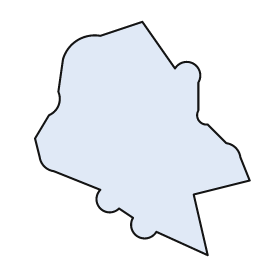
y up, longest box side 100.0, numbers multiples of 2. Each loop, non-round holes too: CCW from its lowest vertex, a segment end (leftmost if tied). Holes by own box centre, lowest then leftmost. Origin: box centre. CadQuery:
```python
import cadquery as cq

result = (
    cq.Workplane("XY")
    .moveTo(28.0, -50.0)
    .lineTo(22.0, -24.0)
    .lineTo(46.0, -18.0)
    .lineTo(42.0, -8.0)
    .threePointArc((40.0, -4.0), (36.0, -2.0))
    .lineTo(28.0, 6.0)
    .threePointArc((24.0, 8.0), (24.0, 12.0))
    .lineTo(24.0, 24.0)
    .threePointArc((22.0, 32.0), (14.0, 30.0))
    .lineTo(0.0, 50.0)
    .lineTo(-18.0, 44.0)
    .threePointArc((-28.0, 42.0), (-34.0, 34.0))
    .lineTo(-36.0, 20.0)
    .threePointArc((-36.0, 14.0), (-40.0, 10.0))
    .lineTo(-46.0, 0.0)
    .lineTo(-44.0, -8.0)
    .threePointArc((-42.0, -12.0), (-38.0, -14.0))
    .lineTo(-18.0, -22.0)
    .threePointArc((-18.0, -30.0), (-10.0, -30.0))
    .lineTo(-4.0, -34.0)
    .threePointArc((-2.0, -42.0), (6.0, -40.0))
    .close()
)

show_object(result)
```